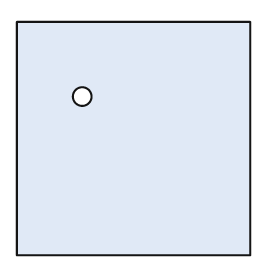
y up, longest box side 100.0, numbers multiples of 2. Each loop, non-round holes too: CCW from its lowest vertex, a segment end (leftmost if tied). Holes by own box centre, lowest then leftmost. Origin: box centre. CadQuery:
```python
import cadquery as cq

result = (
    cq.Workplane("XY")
    .moveTo(-50.0, -50.0)
    .lineTo(50.0, -50.0)
    .lineTo(50.0, 50.0)
    .lineTo(-50.0, 50.0)
    .close()
    .moveTo(-22.0, 18.0)
    .circle(4.0)
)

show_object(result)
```